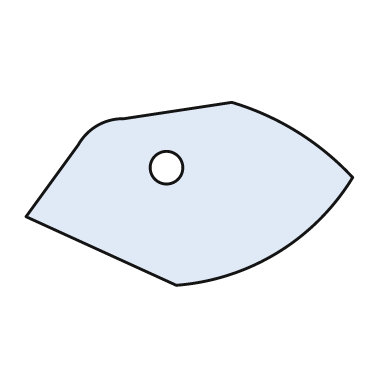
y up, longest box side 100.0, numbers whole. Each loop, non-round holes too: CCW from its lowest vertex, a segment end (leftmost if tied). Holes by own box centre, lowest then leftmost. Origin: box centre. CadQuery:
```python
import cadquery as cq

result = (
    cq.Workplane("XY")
    .moveTo(-4.0, -28.0)
    .threePointArc((27.0, -18.0), (50.0, 5.0))
    .threePointArc((33.0, 19.0), (13.0, 28.0))
    .lineTo(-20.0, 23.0)
    .threePointArc((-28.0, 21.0), (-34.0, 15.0))
    .lineTo(-50.0, -7.0)
    .close()
    .moveTo(-7.0, 8.0)
    .circle(5.0)
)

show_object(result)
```